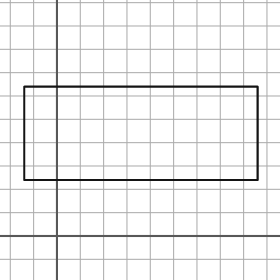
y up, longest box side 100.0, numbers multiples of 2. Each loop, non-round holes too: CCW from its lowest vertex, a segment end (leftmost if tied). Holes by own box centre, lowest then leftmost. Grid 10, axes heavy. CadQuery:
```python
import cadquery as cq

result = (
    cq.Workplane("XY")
    .moveTo(-14.0, 24.0)
    .lineTo(86.0, 24.0)
    .lineTo(86.0, 64.0)
    .lineTo(-14.0, 64.0)
    .close()
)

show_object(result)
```